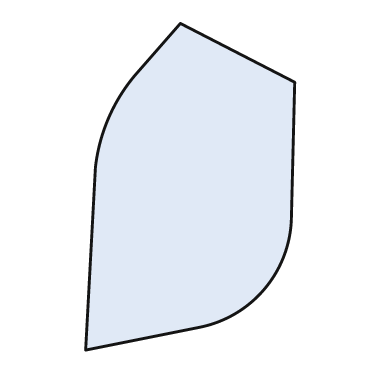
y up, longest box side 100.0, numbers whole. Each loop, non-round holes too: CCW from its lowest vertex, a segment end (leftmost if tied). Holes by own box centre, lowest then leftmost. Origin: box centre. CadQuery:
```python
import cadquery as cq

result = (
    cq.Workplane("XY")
    .moveTo(-32.0, -50.0)
    .lineTo(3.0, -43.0)
    .threePointArc((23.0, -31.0), (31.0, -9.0))
    .lineTo(32.0, 32.0)
    .lineTo(-3.0, 50.0)
    .lineTo(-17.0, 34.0)
    .threePointArc((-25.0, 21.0), (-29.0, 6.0))
    .close()
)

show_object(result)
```